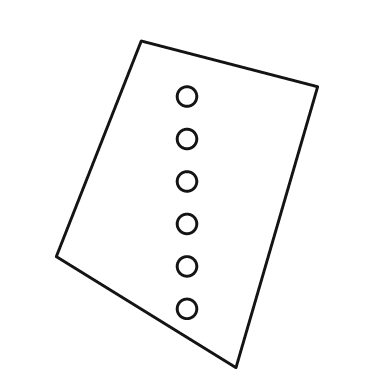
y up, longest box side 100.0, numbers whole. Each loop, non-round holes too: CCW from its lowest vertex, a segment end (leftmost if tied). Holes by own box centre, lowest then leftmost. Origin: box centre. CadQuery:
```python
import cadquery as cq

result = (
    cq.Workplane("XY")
    .moveTo(15.0, -50.0)
    .lineTo(40.0, 36.0)
    .lineTo(-14.0, 50.0)
    .lineTo(-40.0, -16.0)
    .close()
    .moveTo(0.0, -32.0)
    .circle(3.0)
    .moveTo(0.0, -19.0)
    .circle(3.0)
    .moveTo(0.0, -6.0)
    .circle(3.0)
    .moveTo(0.0, 7.0)
    .circle(3.0)
    .moveTo(0.0, 20.0)
    .circle(3.0)
    .moveTo(0.0, 33.0)
    .circle(3.0)
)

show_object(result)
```